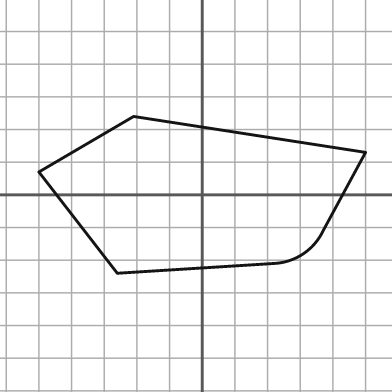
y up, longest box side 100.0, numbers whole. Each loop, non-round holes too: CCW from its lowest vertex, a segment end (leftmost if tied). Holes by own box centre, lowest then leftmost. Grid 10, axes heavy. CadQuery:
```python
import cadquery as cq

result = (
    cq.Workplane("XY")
    .moveTo(-26.0, -24.0)
    .lineTo(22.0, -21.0)
    .threePointArc((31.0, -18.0), (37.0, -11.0))
    .lineTo(50.0, 13.0)
    .lineTo(-21.0, 24.0)
    .lineTo(-50.0, 7.0)
    .close()
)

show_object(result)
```